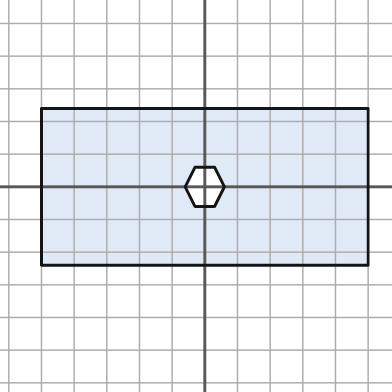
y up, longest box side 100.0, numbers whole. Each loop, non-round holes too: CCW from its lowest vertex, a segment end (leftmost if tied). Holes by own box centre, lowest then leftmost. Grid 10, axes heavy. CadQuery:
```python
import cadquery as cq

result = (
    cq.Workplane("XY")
    .moveTo(-50.0, -24.0)
    .lineTo(50.0, -24.0)
    .lineTo(50.0, 24.0)
    .lineTo(-50.0, 24.0)
    .close()
    .moveTo(-3.0, -6.0)
    .lineTo(3.0, -6.0)
    .lineTo(6.0, 0.0)
    .lineTo(3.0, 6.0)
    .lineTo(-3.0, 6.0)
    .lineTo(-6.0, 0.0)
    .close()
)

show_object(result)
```